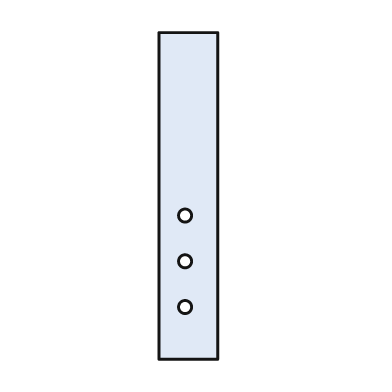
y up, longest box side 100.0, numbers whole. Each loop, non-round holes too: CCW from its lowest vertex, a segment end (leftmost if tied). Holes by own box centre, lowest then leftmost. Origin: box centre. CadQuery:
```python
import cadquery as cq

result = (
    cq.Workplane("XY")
    .moveTo(-9.0, -50.0)
    .lineTo(9.0, -50.0)
    .lineTo(9.0, 50.0)
    .lineTo(-9.0, 50.0)
    .close()
    .moveTo(-1.0, -34.0)
    .circle(2.0)
    .moveTo(-1.0, -20.0)
    .circle(2.0)
    .moveTo(-1.0, -6.0)
    .circle(2.0)
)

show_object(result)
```